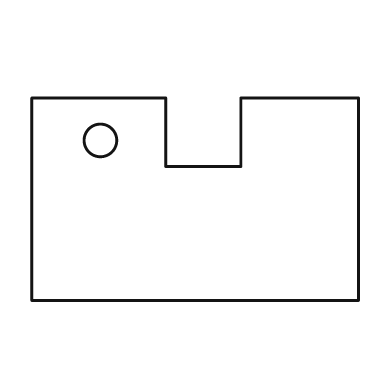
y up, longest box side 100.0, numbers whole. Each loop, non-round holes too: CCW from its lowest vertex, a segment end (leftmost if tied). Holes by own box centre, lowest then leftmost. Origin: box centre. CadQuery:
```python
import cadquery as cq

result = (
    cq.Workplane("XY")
    .moveTo(-50.0, -31.0)
    .lineTo(50.0, -31.0)
    .lineTo(50.0, 31.0)
    .lineTo(14.0, 31.0)
    .lineTo(14.0, 10.0)
    .lineTo(-9.0, 10.0)
    .lineTo(-9.0, 31.0)
    .lineTo(-50.0, 31.0)
    .close()
    .moveTo(-29.0, 18.0)
    .circle(5.0)
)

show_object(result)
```